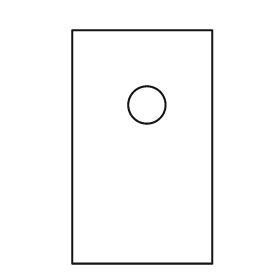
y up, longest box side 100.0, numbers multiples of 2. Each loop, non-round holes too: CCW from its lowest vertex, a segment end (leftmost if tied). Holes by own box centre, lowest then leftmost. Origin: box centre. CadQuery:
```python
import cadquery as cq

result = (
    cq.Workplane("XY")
    .moveTo(-30.0, -50.0)
    .lineTo(30.0, -50.0)
    .lineTo(30.0, 50.0)
    .lineTo(-30.0, 50.0)
    .close()
    .moveTo(2.0, 18.0)
    .circle(8.0)
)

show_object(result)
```